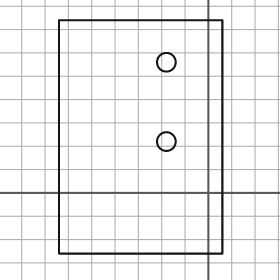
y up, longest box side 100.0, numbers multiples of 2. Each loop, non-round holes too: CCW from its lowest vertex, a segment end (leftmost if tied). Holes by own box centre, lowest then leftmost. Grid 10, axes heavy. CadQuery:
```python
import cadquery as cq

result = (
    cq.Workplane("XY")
    .moveTo(-64.0, -26.0)
    .lineTo(6.0, -26.0)
    .lineTo(6.0, 74.0)
    .lineTo(-64.0, 74.0)
    .close()
    .moveTo(-18.0, 22.0)
    .circle(4.0)
    .moveTo(-18.0, 56.0)
    .circle(4.0)
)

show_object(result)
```